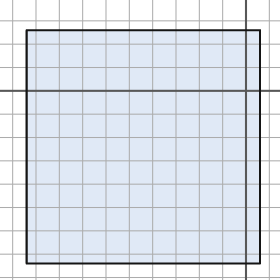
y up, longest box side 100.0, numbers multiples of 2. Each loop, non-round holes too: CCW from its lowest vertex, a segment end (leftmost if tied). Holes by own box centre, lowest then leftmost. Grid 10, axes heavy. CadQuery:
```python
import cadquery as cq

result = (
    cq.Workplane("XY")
    .moveTo(-94.0, -74.0)
    .lineTo(6.0, -74.0)
    .lineTo(6.0, 26.0)
    .lineTo(-94.0, 26.0)
    .close()
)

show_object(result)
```